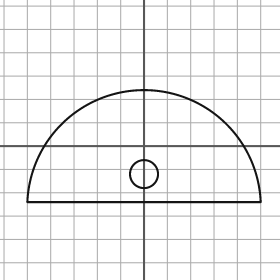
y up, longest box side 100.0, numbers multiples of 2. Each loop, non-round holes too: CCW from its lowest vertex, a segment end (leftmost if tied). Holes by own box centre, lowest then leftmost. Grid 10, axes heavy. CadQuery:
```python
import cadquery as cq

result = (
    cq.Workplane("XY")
    .moveTo(-50.0, -24.0)
    .lineTo(50.0, -24.0)
    .threePointArc((0.0, 24.0), (-50.0, -24.0))
    .close()
    .moveTo(0.0, -12.0)
    .circle(6.0)
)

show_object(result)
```